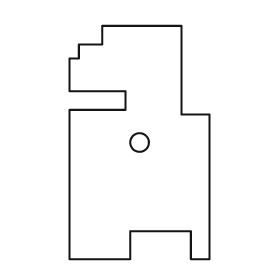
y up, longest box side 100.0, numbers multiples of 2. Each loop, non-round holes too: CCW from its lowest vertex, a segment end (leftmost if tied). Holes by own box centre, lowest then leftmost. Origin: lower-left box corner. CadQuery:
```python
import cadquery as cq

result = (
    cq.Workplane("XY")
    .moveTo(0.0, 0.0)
    .lineTo(26.0, 0.0)
    .lineTo(26.0, 12.0)
    .lineTo(52.0, 12.0)
    .lineTo(52.0, 0.0)
    .lineTo(60.0, 0.0)
    .lineTo(60.0, 62.0)
    .lineTo(48.0, 62.0)
    .lineTo(48.0, 100.0)
    .lineTo(14.0, 100.0)
    .lineTo(14.0, 92.0)
    .lineTo(4.0, 92.0)
    .lineTo(4.0, 86.0)
    .lineTo(0.0, 86.0)
    .lineTo(0.0, 72.0)
    .lineTo(24.0, 72.0)
    .lineTo(24.0, 64.0)
    .lineTo(0.0, 64.0)
    .close()
    .moveTo(30.0, 50.0)
    .circle(4.0)
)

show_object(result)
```